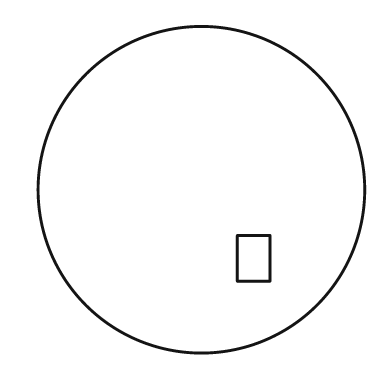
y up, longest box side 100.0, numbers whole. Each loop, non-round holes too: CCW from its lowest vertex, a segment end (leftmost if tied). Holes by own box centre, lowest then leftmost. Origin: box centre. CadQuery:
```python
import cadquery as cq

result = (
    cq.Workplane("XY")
    .moveTo(0.0, 0.0)
    .circle(50.0)
    .moveTo(11.0, -28.0)
    .lineTo(21.0, -28.0)
    .lineTo(21.0, -14.0)
    .lineTo(11.0, -14.0)
    .close()
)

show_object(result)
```